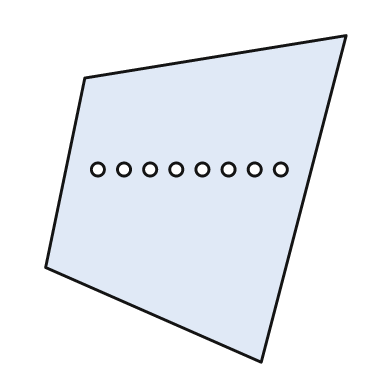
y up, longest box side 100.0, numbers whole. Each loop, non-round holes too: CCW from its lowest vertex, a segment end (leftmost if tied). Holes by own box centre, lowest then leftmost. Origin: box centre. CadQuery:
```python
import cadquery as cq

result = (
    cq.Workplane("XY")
    .moveTo(20.0, -50.0)
    .lineTo(46.0, 50.0)
    .lineTo(-34.0, 37.0)
    .lineTo(-46.0, -21.0)
    .close()
    .moveTo(-30.0, 9.0)
    .circle(2.0)
    .moveTo(-22.0, 9.0)
    .circle(2.0)
    .moveTo(-14.0, 9.0)
    .circle(2.0)
    .moveTo(-6.0, 9.0)
    .circle(2.0)
    .moveTo(2.0, 9.0)
    .circle(2.0)
    .moveTo(10.0, 9.0)
    .circle(2.0)
    .moveTo(18.0, 9.0)
    .circle(2.0)
    .moveTo(26.0, 9.0)
    .circle(2.0)
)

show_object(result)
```